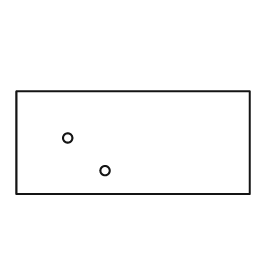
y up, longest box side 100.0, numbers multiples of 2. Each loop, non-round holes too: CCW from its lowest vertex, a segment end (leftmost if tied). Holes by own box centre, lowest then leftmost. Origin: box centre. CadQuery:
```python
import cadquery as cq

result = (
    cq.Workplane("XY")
    .moveTo(-50.0, -22.0)
    .lineTo(50.0, -22.0)
    .lineTo(50.0, 22.0)
    .lineTo(-50.0, 22.0)
    .close()
    .moveTo(-12.0, -12.0)
    .circle(2.0)
    .moveTo(-28.0, 2.0)
    .circle(2.0)
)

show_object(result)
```